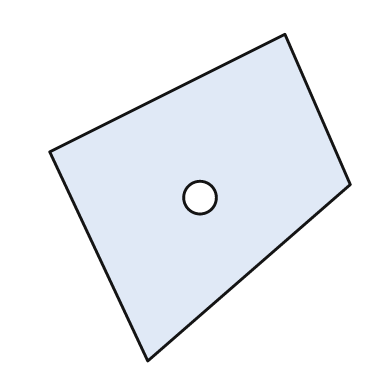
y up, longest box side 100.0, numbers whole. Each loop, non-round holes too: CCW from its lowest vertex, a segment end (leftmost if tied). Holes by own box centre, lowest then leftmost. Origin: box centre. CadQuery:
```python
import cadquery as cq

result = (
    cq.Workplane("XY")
    .moveTo(-16.0, -50.0)
    .lineTo(46.0, 4.0)
    .lineTo(26.0, 50.0)
    .lineTo(-46.0, 14.0)
    .close()
    .moveTo(0.0, 0.0)
    .circle(5.0)
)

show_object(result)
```